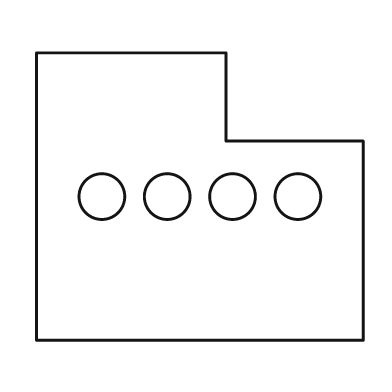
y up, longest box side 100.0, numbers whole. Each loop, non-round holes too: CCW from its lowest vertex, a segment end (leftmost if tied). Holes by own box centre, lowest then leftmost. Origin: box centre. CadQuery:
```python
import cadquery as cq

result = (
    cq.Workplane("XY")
    .moveTo(-50.0, -44.0)
    .lineTo(50.0, -44.0)
    .lineTo(50.0, 17.0)
    .lineTo(8.0, 17.0)
    .lineTo(8.0, 44.0)
    .lineTo(-50.0, 44.0)
    .close()
    .moveTo(-30.0, 0.0)
    .circle(7.0)
    .moveTo(-10.0, 0.0)
    .circle(7.0)
    .moveTo(10.0, 0.0)
    .circle(7.0)
    .moveTo(30.0, 0.0)
    .circle(7.0)
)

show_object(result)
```